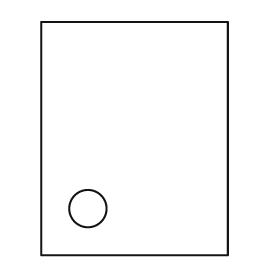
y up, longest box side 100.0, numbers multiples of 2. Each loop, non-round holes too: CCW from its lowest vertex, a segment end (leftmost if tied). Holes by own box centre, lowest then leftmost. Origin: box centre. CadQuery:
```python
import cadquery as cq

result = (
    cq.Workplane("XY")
    .moveTo(-40.0, -50.0)
    .lineTo(40.0, -50.0)
    .lineTo(40.0, 50.0)
    .lineTo(-40.0, 50.0)
    .close()
    .moveTo(-20.0, -30.0)
    .circle(8.0)
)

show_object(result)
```